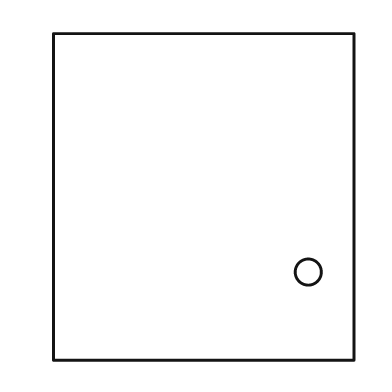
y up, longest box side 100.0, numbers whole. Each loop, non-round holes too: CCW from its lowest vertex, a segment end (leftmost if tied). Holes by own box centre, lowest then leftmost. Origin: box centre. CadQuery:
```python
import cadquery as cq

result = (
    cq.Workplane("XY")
    .moveTo(-46.0, -50.0)
    .lineTo(46.0, -50.0)
    .lineTo(46.0, 50.0)
    .lineTo(-46.0, 50.0)
    .close()
    .moveTo(32.0, -23.0)
    .circle(4.0)
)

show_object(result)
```